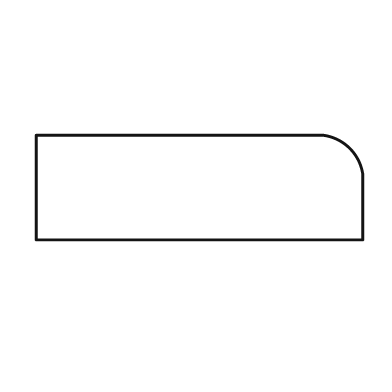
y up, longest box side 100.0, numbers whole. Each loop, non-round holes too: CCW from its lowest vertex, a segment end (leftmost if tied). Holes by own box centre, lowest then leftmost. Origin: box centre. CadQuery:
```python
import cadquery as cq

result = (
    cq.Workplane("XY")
    .moveTo(-50.0, -16.0)
    .lineTo(50.0, -16.0)
    .lineTo(50.0, 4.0)
    .threePointArc((46.0, 12.0), (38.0, 16.0))
    .lineTo(-50.0, 16.0)
    .close()
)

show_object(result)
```